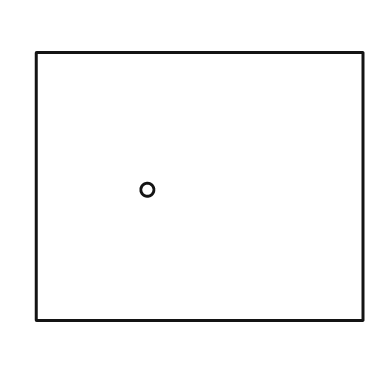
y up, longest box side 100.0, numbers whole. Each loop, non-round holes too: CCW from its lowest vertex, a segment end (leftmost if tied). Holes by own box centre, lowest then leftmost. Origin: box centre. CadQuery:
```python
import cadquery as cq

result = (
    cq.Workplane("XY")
    .moveTo(-50.0, -41.0)
    .lineTo(50.0, -41.0)
    .lineTo(50.0, 41.0)
    .lineTo(-50.0, 41.0)
    .close()
    .moveTo(-16.0, -1.0)
    .circle(2.0)
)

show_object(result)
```